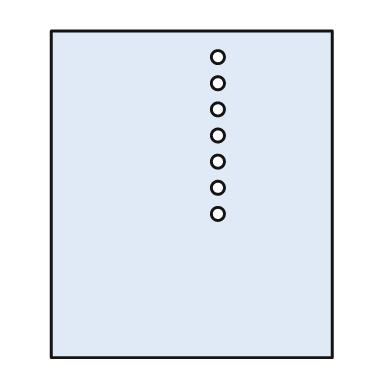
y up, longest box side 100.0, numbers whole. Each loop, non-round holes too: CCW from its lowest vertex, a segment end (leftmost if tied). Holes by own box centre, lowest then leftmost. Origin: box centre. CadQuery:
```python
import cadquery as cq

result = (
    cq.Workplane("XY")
    .moveTo(-43.0, -50.0)
    .lineTo(43.0, -50.0)
    .lineTo(43.0, 50.0)
    .lineTo(-43.0, 50.0)
    .close()
    .moveTo(8.0, -6.0)
    .circle(2.0)
    .moveTo(8.0, 2.0)
    .circle(2.0)
    .moveTo(8.0, 10.0)
    .circle(2.0)
    .moveTo(8.0, 18.0)
    .circle(2.0)
    .moveTo(8.0, 26.0)
    .circle(2.0)
    .moveTo(8.0, 34.0)
    .circle(2.0)
    .moveTo(8.0, 42.0)
    .circle(2.0)
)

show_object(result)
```